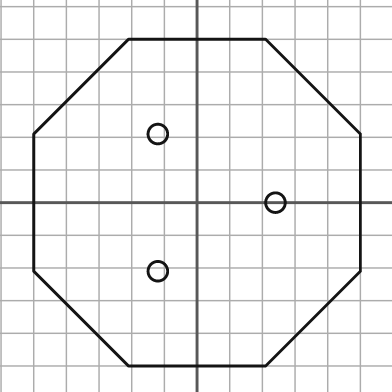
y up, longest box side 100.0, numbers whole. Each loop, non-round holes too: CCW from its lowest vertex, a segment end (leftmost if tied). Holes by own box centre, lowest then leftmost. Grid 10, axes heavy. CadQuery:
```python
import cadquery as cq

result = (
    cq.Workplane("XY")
    .moveTo(-21.0, -50.0)
    .lineTo(21.0, -50.0)
    .lineTo(50.0, -21.0)
    .lineTo(50.0, 21.0)
    .lineTo(21.0, 50.0)
    .lineTo(-21.0, 50.0)
    .lineTo(-50.0, 21.0)
    .lineTo(-50.0, -21.0)
    .close()
    .moveTo(-12.0, -21.0)
    .circle(3.0)
    .moveTo(24.0, 0.0)
    .circle(3.0)
    .moveTo(-12.0, 21.0)
    .circle(3.0)
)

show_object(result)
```